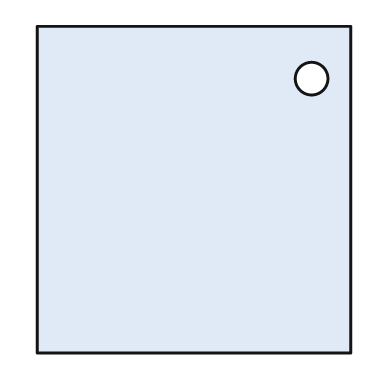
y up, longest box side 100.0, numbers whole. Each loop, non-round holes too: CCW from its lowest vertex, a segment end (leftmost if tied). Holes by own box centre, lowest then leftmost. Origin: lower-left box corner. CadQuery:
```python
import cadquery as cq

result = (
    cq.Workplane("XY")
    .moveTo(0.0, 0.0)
    .lineTo(96.0, 0.0)
    .lineTo(96.0, 100.0)
    .lineTo(0.0, 100.0)
    .close()
    .moveTo(84.0, 84.0)
    .circle(5.0)
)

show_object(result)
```